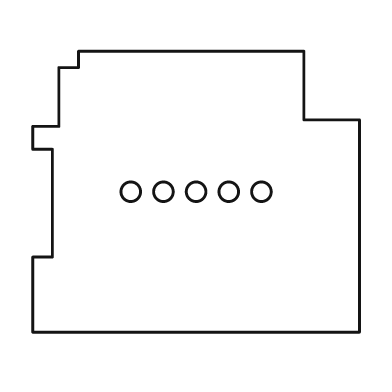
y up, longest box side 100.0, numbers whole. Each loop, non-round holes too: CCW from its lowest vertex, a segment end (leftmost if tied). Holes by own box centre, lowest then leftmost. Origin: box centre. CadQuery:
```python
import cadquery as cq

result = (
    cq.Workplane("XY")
    .moveTo(-50.0, -43.0)
    .lineTo(50.0, -43.0)
    .lineTo(50.0, 22.0)
    .lineTo(33.0, 22.0)
    .lineTo(33.0, 43.0)
    .lineTo(-36.0, 43.0)
    .lineTo(-36.0, 38.0)
    .lineTo(-42.0, 38.0)
    .lineTo(-42.0, 20.0)
    .lineTo(-50.0, 20.0)
    .lineTo(-50.0, 13.0)
    .lineTo(-44.0, 13.0)
    .lineTo(-44.0, -20.0)
    .lineTo(-50.0, -20.0)
    .close()
    .moveTo(-20.0, 0.0)
    .circle(3.0)
    .moveTo(-10.0, 0.0)
    .circle(3.0)
    .moveTo(0.0, 0.0)
    .circle(3.0)
    .moveTo(10.0, 0.0)
    .circle(3.0)
    .moveTo(20.0, 0.0)
    .circle(3.0)
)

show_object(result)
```